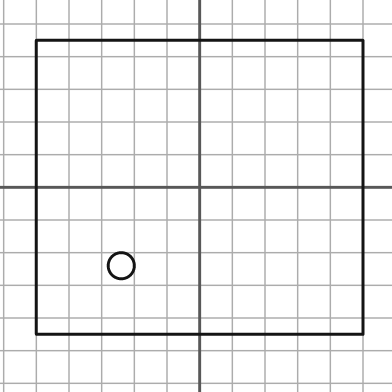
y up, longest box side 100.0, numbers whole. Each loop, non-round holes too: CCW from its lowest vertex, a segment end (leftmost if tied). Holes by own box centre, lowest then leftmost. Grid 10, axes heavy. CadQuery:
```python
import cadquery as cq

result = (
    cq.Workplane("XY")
    .moveTo(-50.0, -45.0)
    .lineTo(50.0, -45.0)
    .lineTo(50.0, 45.0)
    .lineTo(-50.0, 45.0)
    .close()
    .moveTo(-24.0, -24.0)
    .circle(4.0)
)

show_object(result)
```